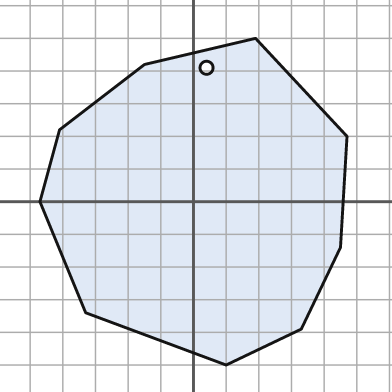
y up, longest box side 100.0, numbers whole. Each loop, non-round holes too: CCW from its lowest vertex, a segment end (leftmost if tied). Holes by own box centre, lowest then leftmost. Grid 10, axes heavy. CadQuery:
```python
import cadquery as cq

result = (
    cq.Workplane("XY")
    .moveTo(10.0, -50.0)
    .lineTo(33.0, -39.0)
    .lineTo(45.0, -14.0)
    .lineTo(47.0, 20.0)
    .lineTo(19.0, 50.0)
    .lineTo(-15.0, 42.0)
    .lineTo(-41.0, 22.0)
    .lineTo(-47.0, 0.0)
    .lineTo(-33.0, -34.0)
    .close()
    .moveTo(4.0, 41.0)
    .circle(2.0)
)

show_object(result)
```